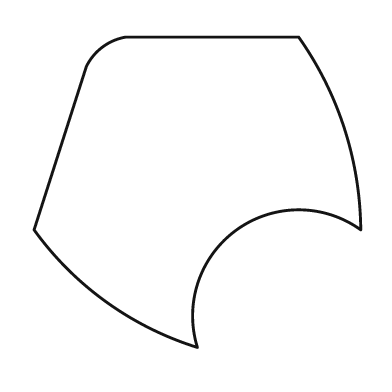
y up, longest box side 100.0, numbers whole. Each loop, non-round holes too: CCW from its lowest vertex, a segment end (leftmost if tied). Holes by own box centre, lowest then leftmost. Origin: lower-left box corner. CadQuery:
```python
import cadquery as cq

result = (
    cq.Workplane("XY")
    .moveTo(50.0, 0.0)
    .threePointArc((62.0, 36.0), (100.0, 36.0))
    .threePointArc((95.0, 67.0), (81.0, 95.0))
    .lineTo(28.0, 95.0)
    .threePointArc((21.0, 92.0), (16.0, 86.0))
    .lineTo(0.0, 36.0)
    .threePointArc((22.0, 14.0), (50.0, 0.0))
    .close()
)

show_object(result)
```